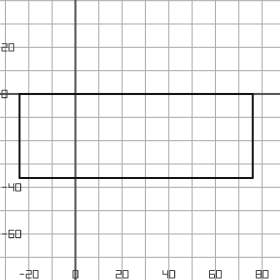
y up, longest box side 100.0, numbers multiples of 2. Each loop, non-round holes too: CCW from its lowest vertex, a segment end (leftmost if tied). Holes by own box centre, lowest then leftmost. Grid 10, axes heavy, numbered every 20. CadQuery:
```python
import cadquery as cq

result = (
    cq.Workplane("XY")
    .moveTo(-24.0, -36.0)
    .lineTo(76.0, -36.0)
    .lineTo(76.0, 0.0)
    .lineTo(-24.0, 0.0)
    .close()
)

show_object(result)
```